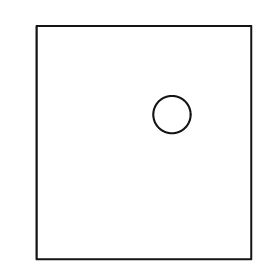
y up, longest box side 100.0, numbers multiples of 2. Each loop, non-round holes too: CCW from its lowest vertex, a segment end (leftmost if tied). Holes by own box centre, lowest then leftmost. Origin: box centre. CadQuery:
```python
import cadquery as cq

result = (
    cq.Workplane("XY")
    .moveTo(-46.0, -50.0)
    .lineTo(46.0, -50.0)
    .lineTo(46.0, 50.0)
    .lineTo(-46.0, 50.0)
    .close()
    .moveTo(12.0, 12.0)
    .circle(8.0)
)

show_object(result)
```